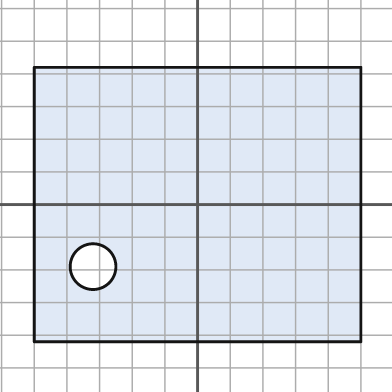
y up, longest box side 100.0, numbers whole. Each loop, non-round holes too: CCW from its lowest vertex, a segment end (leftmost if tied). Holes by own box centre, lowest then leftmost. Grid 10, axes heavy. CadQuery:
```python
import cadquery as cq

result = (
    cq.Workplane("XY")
    .moveTo(-50.0, -42.0)
    .lineTo(50.0, -42.0)
    .lineTo(50.0, 42.0)
    .lineTo(-50.0, 42.0)
    .close()
    .moveTo(-32.0, -19.0)
    .circle(7.0)
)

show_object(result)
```